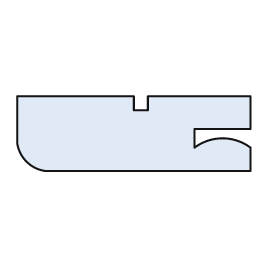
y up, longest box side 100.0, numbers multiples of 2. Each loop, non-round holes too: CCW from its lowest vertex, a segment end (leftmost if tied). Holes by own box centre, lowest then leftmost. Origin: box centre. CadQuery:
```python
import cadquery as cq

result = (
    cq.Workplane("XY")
    .moveTo(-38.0, -16.0)
    .lineTo(50.0, -16.0)
    .lineTo(50.0, -6.0)
    .threePointArc((38.0, -2.0), (26.0, -6.0))
    .lineTo(26.0, 2.0)
    .lineTo(50.0, 2.0)
    .lineTo(50.0, 16.0)
    .lineTo(6.0, 16.0)
    .lineTo(6.0, 10.0)
    .lineTo(0.0, 10.0)
    .lineTo(0.0, 16.0)
    .lineTo(-50.0, 16.0)
    .lineTo(-50.0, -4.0)
    .threePointArc((-46.0, -12.0), (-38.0, -16.0))
    .close()
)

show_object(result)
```